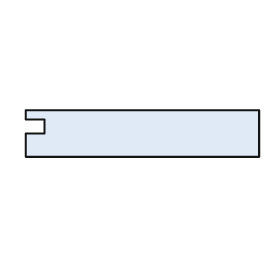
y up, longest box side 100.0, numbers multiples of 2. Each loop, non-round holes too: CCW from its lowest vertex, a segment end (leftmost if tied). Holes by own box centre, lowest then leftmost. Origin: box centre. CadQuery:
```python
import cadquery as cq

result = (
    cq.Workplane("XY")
    .moveTo(-50.0, -10.0)
    .lineTo(50.0, -10.0)
    .lineTo(50.0, 10.0)
    .lineTo(-50.0, 10.0)
    .lineTo(-50.0, 6.0)
    .lineTo(-42.0, 6.0)
    .lineTo(-42.0, 0.0)
    .lineTo(-50.0, 0.0)
    .close()
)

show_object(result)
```